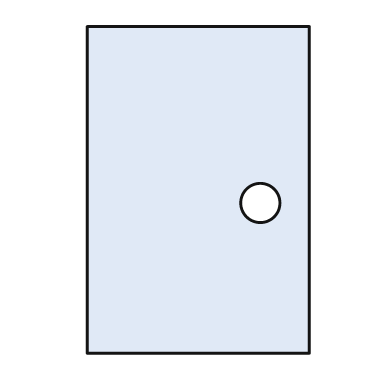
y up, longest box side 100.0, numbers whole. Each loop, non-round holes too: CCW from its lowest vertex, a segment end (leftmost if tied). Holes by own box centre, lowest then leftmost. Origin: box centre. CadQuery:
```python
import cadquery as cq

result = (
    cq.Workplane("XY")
    .moveTo(-34.0, -50.0)
    .lineTo(34.0, -50.0)
    .lineTo(34.0, 50.0)
    .lineTo(-34.0, 50.0)
    .close()
    .moveTo(19.0, -4.0)
    .circle(6.0)
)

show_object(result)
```